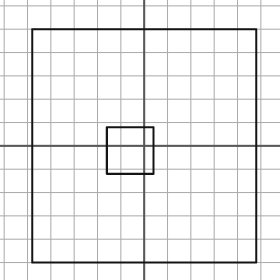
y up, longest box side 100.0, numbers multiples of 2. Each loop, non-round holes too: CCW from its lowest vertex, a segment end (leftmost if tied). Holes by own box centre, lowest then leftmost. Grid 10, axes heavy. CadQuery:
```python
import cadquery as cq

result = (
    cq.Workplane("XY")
    .moveTo(-48.0, -50.0)
    .lineTo(48.0, -50.0)
    .lineTo(48.0, 50.0)
    .lineTo(-48.0, 50.0)
    .close()
    .moveTo(-16.0, -12.0)
    .lineTo(4.0, -12.0)
    .lineTo(4.0, 8.0)
    .lineTo(-16.0, 8.0)
    .close()
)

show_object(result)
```